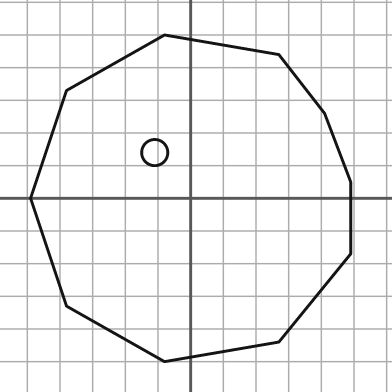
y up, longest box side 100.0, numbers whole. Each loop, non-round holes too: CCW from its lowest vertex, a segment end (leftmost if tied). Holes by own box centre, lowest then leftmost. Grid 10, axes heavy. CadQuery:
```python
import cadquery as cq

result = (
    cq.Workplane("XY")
    .moveTo(-8.0, -50.0)
    .lineTo(27.0, -44.0)
    .lineTo(49.0, -17.0)
    .lineTo(49.0, 5.0)
    .lineTo(41.0, 26.0)
    .lineTo(27.0, 44.0)
    .lineTo(-8.0, 50.0)
    .lineTo(-38.0, 33.0)
    .lineTo(-49.0, 0.0)
    .lineTo(-38.0, -33.0)
    .close()
    .moveTo(-11.0, 14.0)
    .circle(4.0)
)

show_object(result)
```